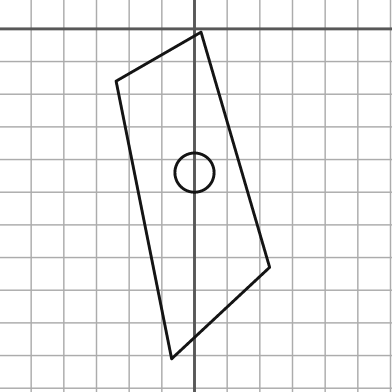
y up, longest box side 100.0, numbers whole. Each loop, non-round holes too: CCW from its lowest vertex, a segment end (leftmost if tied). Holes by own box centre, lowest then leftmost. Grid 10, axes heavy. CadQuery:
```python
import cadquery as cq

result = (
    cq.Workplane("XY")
    .moveTo(-7.0, -101.0)
    .lineTo(23.0, -73.0)
    .lineTo(2.0, -1.0)
    .lineTo(-24.0, -16.0)
    .close()
    .moveTo(0.0, -44.0)
    .circle(6.0)
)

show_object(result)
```